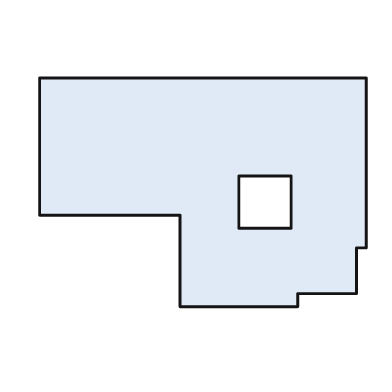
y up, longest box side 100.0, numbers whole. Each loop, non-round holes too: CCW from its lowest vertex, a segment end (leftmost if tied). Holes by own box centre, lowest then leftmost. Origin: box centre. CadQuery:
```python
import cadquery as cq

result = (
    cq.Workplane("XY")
    .moveTo(-7.0, -35.0)
    .lineTo(29.0, -35.0)
    .lineTo(29.0, -31.0)
    .lineTo(47.0, -31.0)
    .lineTo(47.0, -17.0)
    .lineTo(50.0, -17.0)
    .lineTo(50.0, 35.0)
    .lineTo(-50.0, 35.0)
    .lineTo(-50.0, -7.0)
    .lineTo(-7.0, -7.0)
    .close()
    .moveTo(11.0, -11.0)
    .lineTo(27.0, -11.0)
    .lineTo(27.0, 5.0)
    .lineTo(11.0, 5.0)
    .close()
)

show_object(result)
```